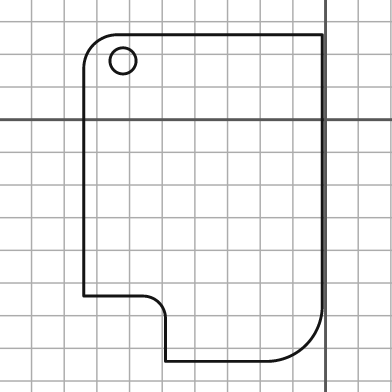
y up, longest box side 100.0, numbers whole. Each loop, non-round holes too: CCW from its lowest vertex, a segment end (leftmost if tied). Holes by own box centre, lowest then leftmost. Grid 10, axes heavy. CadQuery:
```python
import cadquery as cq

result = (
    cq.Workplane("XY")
    .moveTo(-49.0, -74.0)
    .lineTo(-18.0, -74.0)
    .threePointArc((-6.0, -69.0), (-1.0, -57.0))
    .lineTo(-1.0, 26.0)
    .lineTo(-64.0, 26.0)
    .threePointArc((-71.0, 23.0), (-74.0, 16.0))
    .lineTo(-74.0, -54.0)
    .lineTo(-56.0, -54.0)
    .threePointArc((-51.0, -56.0), (-49.0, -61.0))
    .close()
    .moveTo(-62.0, 18.0)
    .circle(4.0)
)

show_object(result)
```